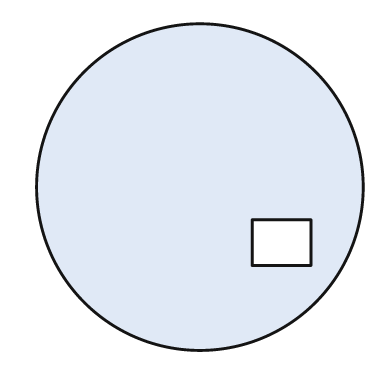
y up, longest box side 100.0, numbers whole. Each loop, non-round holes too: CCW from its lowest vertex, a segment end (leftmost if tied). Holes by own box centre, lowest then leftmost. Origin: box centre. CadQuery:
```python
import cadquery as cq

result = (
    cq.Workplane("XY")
    .moveTo(0.0, 0.0)
    .circle(50.0)
    .moveTo(16.0, -24.0)
    .lineTo(34.0, -24.0)
    .lineTo(34.0, -10.0)
    .lineTo(16.0, -10.0)
    .close()
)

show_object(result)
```